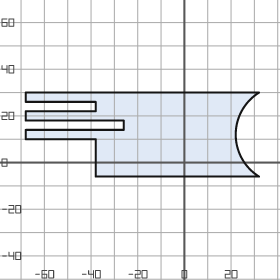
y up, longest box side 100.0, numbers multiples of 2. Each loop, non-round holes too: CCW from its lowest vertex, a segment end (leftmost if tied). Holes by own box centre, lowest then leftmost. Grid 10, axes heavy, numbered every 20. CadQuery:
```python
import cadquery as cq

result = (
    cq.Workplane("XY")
    .moveTo(-38.0, -6.0)
    .lineTo(32.0, -6.0)
    .threePointArc((22.0, 12.0), (32.0, 30.0))
    .lineTo(-68.0, 30.0)
    .lineTo(-68.0, 26.0)
    .lineTo(-38.0, 26.0)
    .lineTo(-38.0, 22.0)
    .lineTo(-68.0, 22.0)
    .lineTo(-68.0, 18.0)
    .lineTo(-26.0, 18.0)
    .lineTo(-26.0, 14.0)
    .lineTo(-68.0, 14.0)
    .lineTo(-68.0, 10.0)
    .lineTo(-38.0, 10.0)
    .close()
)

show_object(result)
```